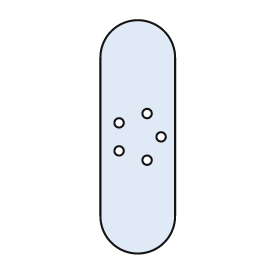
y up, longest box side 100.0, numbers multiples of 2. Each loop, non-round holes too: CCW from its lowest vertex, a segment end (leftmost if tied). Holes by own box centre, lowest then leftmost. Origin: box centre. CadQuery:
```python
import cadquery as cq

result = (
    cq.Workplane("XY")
    .moveTo(-16.0, -34.0)
    .threePointArc((0.0, -50.0), (16.0, -34.0))
    .lineTo(16.0, 34.0)
    .threePointArc((0.0, 50.0), (-16.0, 34.0))
    .close()
    .moveTo(4.0, -10.0)
    .circle(2.0)
    .moveTo(-8.0, -6.0)
    .circle(2.0)
    .moveTo(10.0, 0.0)
    .circle(2.0)
    .moveTo(-8.0, 6.0)
    .circle(2.0)
    .moveTo(4.0, 10.0)
    .circle(2.0)
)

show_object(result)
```